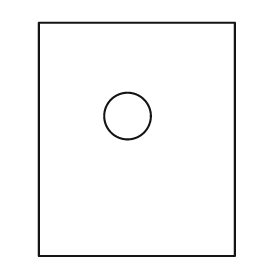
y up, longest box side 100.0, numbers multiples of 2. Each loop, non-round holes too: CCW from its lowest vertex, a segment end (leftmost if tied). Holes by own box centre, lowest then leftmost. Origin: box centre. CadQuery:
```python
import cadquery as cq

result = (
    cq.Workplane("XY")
    .moveTo(-42.0, -50.0)
    .lineTo(42.0, -50.0)
    .lineTo(42.0, 50.0)
    .lineTo(-42.0, 50.0)
    .close()
    .moveTo(-4.0, 10.0)
    .circle(10.0)
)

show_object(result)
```